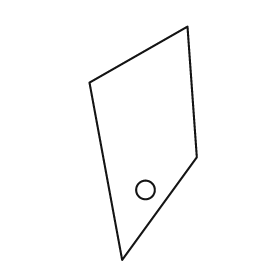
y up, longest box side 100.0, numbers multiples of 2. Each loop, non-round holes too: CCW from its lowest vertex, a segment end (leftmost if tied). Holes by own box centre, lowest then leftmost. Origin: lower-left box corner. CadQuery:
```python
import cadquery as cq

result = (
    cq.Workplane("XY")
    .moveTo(14.0, 0.0)
    .lineTo(46.0, 44.0)
    .lineTo(42.0, 100.0)
    .lineTo(0.0, 76.0)
    .close()
    .moveTo(24.0, 30.0)
    .circle(4.0)
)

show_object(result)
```